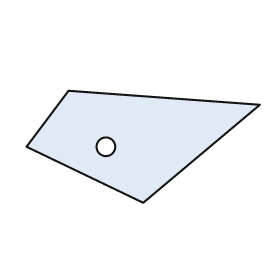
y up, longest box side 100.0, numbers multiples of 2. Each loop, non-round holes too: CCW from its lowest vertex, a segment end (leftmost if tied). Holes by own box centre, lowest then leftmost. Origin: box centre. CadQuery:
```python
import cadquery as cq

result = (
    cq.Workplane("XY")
    .moveTo(0.0, -24.0)
    .lineTo(50.0, 18.0)
    .lineTo(-32.0, 24.0)
    .lineTo(-50.0, 0.0)
    .close()
    .moveTo(-16.0, 0.0)
    .circle(4.0)
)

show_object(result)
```